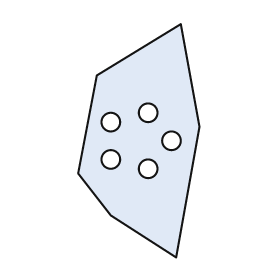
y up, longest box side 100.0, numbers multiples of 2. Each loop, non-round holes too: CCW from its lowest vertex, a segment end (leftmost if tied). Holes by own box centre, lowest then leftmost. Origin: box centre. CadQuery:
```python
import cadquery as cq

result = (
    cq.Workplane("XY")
    .moveTo(16.0, -50.0)
    .lineTo(26.0, 6.0)
    .lineTo(18.0, 50.0)
    .lineTo(-18.0, 28.0)
    .lineTo(-26.0, -14.0)
    .lineTo(-12.0, -32.0)
    .close()
    .moveTo(4.0, -12.0)
    .circle(4.0)
    .moveTo(-12.0, -8.0)
    .circle(4.0)
    .moveTo(14.0, 0.0)
    .circle(4.0)
    .moveTo(-12.0, 8.0)
    .circle(4.0)
    .moveTo(4.0, 12.0)
    .circle(4.0)
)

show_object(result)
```